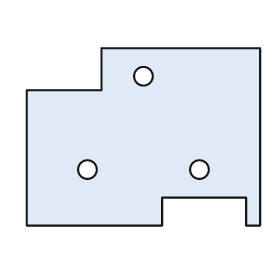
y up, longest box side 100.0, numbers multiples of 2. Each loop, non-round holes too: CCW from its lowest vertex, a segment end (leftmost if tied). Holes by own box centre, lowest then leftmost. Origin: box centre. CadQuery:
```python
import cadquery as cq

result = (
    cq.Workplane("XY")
    .moveTo(-50.0, -38.0)
    .lineTo(8.0, -38.0)
    .lineTo(8.0, -26.0)
    .lineTo(44.0, -26.0)
    .lineTo(44.0, -38.0)
    .lineTo(50.0, -38.0)
    .lineTo(50.0, 38.0)
    .lineTo(-18.0, 38.0)
    .lineTo(-18.0, 20.0)
    .lineTo(-50.0, 20.0)
    .close()
    .moveTo(-24.0, -14.0)
    .circle(4.0)
    .moveTo(24.0, -14.0)
    .circle(4.0)
    .moveTo(0.0, 26.0)
    .circle(4.0)
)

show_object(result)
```